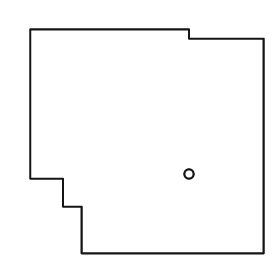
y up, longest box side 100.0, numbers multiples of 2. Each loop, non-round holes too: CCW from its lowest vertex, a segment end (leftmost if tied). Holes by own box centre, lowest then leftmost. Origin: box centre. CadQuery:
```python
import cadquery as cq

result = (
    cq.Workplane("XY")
    .moveTo(-28.0, -48.0)
    .lineTo(50.0, -48.0)
    .lineTo(50.0, 44.0)
    .lineTo(18.0, 44.0)
    .lineTo(18.0, 48.0)
    .lineTo(-50.0, 48.0)
    .lineTo(-50.0, -16.0)
    .lineTo(-36.0, -16.0)
    .lineTo(-36.0, -28.0)
    .lineTo(-28.0, -28.0)
    .close()
    .moveTo(18.0, -14.0)
    .circle(2.0)
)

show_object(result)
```